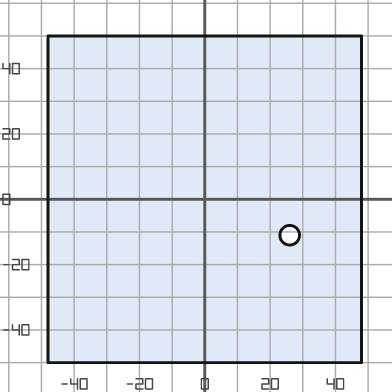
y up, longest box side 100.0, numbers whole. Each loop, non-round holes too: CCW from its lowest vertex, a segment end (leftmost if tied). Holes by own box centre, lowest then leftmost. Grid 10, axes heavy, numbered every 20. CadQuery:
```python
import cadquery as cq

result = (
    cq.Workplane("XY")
    .moveTo(-48.0, -50.0)
    .lineTo(48.0, -50.0)
    .lineTo(48.0, 50.0)
    .lineTo(-48.0, 50.0)
    .close()
    .moveTo(26.0, -11.0)
    .circle(3.0)
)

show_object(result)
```